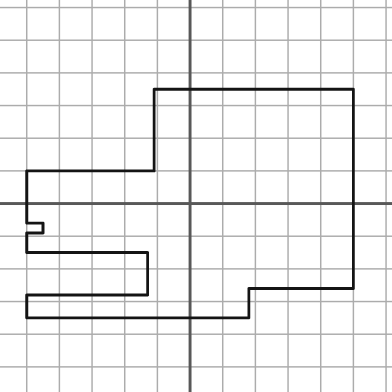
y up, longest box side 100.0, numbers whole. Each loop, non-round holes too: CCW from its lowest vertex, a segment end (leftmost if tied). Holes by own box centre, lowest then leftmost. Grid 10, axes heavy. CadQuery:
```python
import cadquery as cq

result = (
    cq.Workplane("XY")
    .moveTo(-50.0, -35.0)
    .lineTo(18.0, -35.0)
    .lineTo(18.0, -26.0)
    .lineTo(50.0, -26.0)
    .lineTo(50.0, 35.0)
    .lineTo(-11.0, 35.0)
    .lineTo(-11.0, 10.0)
    .lineTo(-50.0, 10.0)
    .lineTo(-50.0, -6.0)
    .lineTo(-45.0, -6.0)
    .lineTo(-45.0, -9.0)
    .lineTo(-50.0, -9.0)
    .lineTo(-50.0, -15.0)
    .lineTo(-13.0, -15.0)
    .lineTo(-13.0, -28.0)
    .lineTo(-50.0, -28.0)
    .close()
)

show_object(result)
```